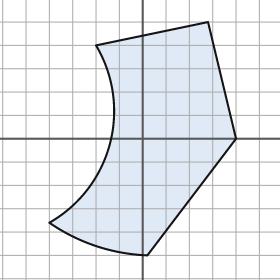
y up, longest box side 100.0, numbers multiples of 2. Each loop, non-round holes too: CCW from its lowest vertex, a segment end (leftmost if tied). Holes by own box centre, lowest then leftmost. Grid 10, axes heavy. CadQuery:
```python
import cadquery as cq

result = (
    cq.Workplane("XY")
    .moveTo(2.0, -50.0)
    .lineTo(40.0, 0.0)
    .lineTo(28.0, 50.0)
    .lineTo(-20.0, 40.0)
    .threePointArc((-14.0, -2.0), (-40.0, -36.0))
    .threePointArc((-20.0, -46.0), (2.0, -50.0))
    .close()
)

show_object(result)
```